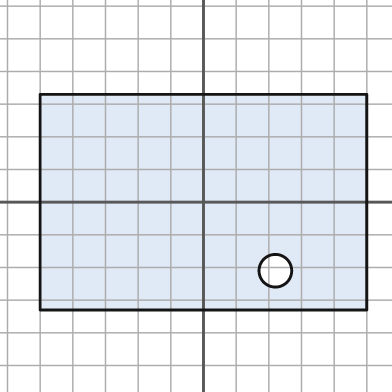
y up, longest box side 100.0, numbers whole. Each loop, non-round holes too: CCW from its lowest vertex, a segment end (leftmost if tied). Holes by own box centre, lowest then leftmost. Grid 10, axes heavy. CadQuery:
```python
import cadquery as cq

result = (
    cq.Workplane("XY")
    .moveTo(-50.0, -33.0)
    .lineTo(50.0, -33.0)
    .lineTo(50.0, 33.0)
    .lineTo(-50.0, 33.0)
    .close()
    .moveTo(22.0, -21.0)
    .circle(5.0)
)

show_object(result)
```